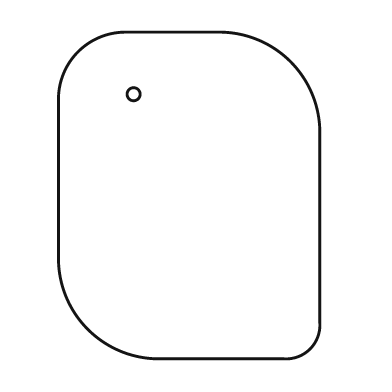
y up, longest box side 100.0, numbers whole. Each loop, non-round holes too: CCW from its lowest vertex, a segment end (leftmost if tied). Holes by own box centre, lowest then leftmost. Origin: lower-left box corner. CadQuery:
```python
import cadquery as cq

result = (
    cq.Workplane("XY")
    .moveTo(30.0, 0.0)
    .lineTo(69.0, 0.0)
    .threePointArc((77.0, 3.0), (80.0, 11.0))
    .lineTo(80.0, 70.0)
    .threePointArc((71.0, 91.0), (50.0, 100.0))
    .lineTo(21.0, 100.0)
    .threePointArc((6.0, 94.0), (0.0, 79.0))
    .lineTo(0.0, 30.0)
    .threePointArc((9.0, 9.0), (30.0, 0.0))
    .close()
    .moveTo(23.0, 81.0)
    .circle(2.0)
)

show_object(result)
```